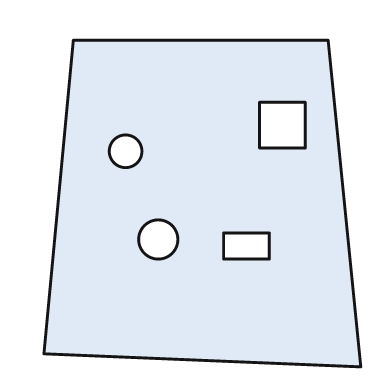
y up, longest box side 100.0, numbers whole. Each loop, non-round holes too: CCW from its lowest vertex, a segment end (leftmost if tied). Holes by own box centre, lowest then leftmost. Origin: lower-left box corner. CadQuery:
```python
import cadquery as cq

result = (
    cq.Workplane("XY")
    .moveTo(97.0, 0.0)
    .lineTo(87.0, 100.0)
    .lineTo(9.0, 100.0)
    .lineTo(0.0, 4.0)
    .close()
    .moveTo(55.0, 33.0)
    .lineTo(69.0, 33.0)
    .lineTo(69.0, 41.0)
    .lineTo(55.0, 41.0)
    .close()
    .moveTo(35.0, 39.0)
    .circle(6.0)
    .moveTo(25.0, 66.0)
    .circle(5.0)
    .moveTo(66.0, 67.0)
    .lineTo(80.0, 67.0)
    .lineTo(80.0, 81.0)
    .lineTo(66.0, 81.0)
    .close()
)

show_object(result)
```